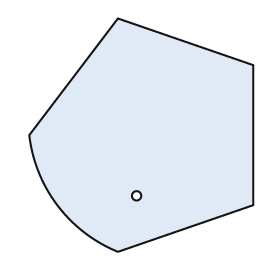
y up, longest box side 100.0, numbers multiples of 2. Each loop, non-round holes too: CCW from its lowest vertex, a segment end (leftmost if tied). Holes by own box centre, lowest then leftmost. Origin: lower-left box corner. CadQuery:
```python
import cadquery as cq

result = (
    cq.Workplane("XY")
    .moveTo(38.0, 0.0)
    .lineTo(96.0, 20.0)
    .lineTo(96.0, 80.0)
    .lineTo(38.0, 100.0)
    .lineTo(0.0, 50.0)
    .threePointArc((12.0, 20.0), (38.0, 0.0))
    .close()
    .moveTo(46.0, 24.0)
    .circle(2.0)
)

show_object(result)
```